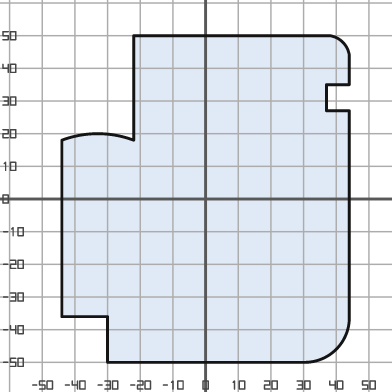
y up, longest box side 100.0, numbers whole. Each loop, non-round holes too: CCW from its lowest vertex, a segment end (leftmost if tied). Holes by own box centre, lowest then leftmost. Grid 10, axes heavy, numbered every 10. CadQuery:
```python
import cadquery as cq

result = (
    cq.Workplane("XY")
    .moveTo(-30.0, -50.0)
    .lineTo(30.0, -50.0)
    .threePointArc((40.0, -46.0), (44.0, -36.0))
    .lineTo(44.0, 27.0)
    .lineTo(37.0, 27.0)
    .lineTo(37.0, 35.0)
    .lineTo(44.0, 35.0)
    .lineTo(44.0, 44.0)
    .threePointArc((42.0, 48.0), (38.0, 50.0))
    .lineTo(-22.0, 50.0)
    .lineTo(-22.0, 18.0)
    .threePointArc((-33.0, 20.0), (-44.0, 18.0))
    .lineTo(-44.0, -36.0)
    .lineTo(-30.0, -36.0)
    .close()
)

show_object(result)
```